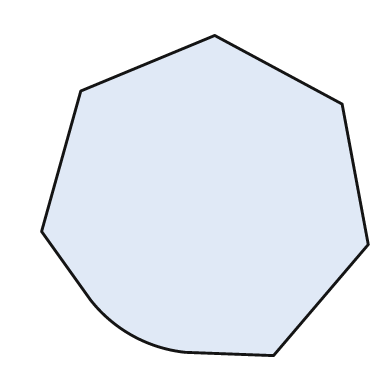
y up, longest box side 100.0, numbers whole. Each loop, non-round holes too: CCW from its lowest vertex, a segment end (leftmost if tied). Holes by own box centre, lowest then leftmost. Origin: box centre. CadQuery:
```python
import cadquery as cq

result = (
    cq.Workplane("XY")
    .moveTo(21.0, -49.0)
    .lineTo(50.0, -15.0)
    .lineTo(42.0, 28.0)
    .lineTo(3.0, 49.0)
    .lineTo(-38.0, 32.0)
    .lineTo(-50.0, -11.0)
    .lineTo(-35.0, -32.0)
    .threePointArc((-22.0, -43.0), (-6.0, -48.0))
    .close()
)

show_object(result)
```